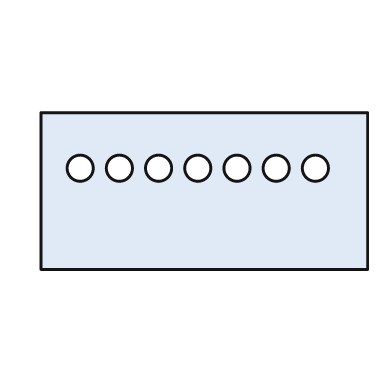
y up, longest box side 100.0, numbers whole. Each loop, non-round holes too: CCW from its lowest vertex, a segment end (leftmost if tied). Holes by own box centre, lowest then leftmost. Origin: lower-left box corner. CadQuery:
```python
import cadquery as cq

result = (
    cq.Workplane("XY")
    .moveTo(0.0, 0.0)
    .lineTo(100.0, 0.0)
    .lineTo(100.0, 48.0)
    .lineTo(0.0, 48.0)
    .close()
    .moveTo(12.0, 31.0)
    .circle(4.0)
    .moveTo(24.0, 31.0)
    .circle(4.0)
    .moveTo(36.0, 31.0)
    .circle(4.0)
    .moveTo(48.0, 31.0)
    .circle(4.0)
    .moveTo(60.0, 31.0)
    .circle(4.0)
    .moveTo(72.0, 31.0)
    .circle(4.0)
    .moveTo(84.0, 31.0)
    .circle(4.0)
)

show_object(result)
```